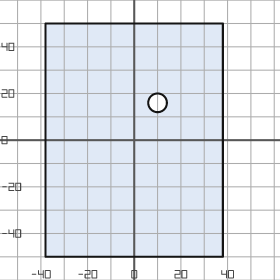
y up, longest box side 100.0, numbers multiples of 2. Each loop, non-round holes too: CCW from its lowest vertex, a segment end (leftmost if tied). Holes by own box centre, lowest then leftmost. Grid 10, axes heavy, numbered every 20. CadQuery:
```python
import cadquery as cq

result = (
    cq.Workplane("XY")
    .moveTo(-38.0, -50.0)
    .lineTo(38.0, -50.0)
    .lineTo(38.0, 50.0)
    .lineTo(-38.0, 50.0)
    .close()
    .moveTo(10.0, 16.0)
    .circle(4.0)
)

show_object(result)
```